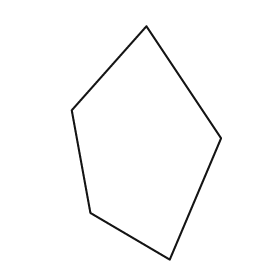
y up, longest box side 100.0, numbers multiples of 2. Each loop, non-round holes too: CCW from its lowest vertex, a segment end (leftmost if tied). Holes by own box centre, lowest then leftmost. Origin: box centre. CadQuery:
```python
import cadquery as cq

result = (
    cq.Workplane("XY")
    .moveTo(10.0, -50.0)
    .lineTo(32.0, 2.0)
    .lineTo(0.0, 50.0)
    .lineTo(-32.0, 14.0)
    .lineTo(-24.0, -30.0)
    .close()
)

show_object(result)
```